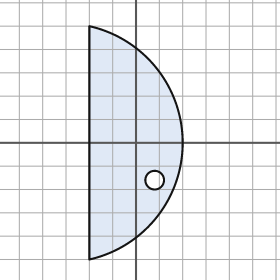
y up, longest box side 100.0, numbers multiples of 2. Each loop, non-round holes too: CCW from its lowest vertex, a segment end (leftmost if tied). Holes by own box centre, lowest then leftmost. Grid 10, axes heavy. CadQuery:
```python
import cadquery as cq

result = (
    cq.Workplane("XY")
    .moveTo(-20.0, -50.0)
    .threePointArc((20.0, 0.0), (-20.0, 50.0))
    .close()
    .moveTo(8.0, -16.0)
    .circle(4.0)
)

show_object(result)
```